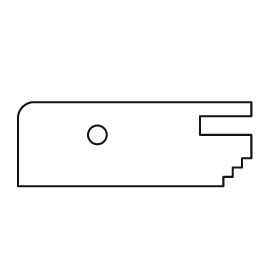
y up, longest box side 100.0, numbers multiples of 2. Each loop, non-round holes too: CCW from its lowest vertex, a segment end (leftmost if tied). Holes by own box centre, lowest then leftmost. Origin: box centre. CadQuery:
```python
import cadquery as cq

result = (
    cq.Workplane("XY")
    .moveTo(-50.0, -18.0)
    .lineTo(38.0, -18.0)
    .lineTo(38.0, -14.0)
    .lineTo(42.0, -14.0)
    .lineTo(42.0, -10.0)
    .lineTo(46.0, -10.0)
    .lineTo(46.0, -6.0)
    .lineTo(50.0, -6.0)
    .lineTo(50.0, 4.0)
    .lineTo(28.0, 4.0)
    .lineTo(28.0, 12.0)
    .lineTo(50.0, 12.0)
    .lineTo(50.0, 18.0)
    .lineTo(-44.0, 18.0)
    .threePointArc((-48.0, 16.0), (-50.0, 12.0))
    .close()
    .moveTo(-16.0, 4.0)
    .circle(4.0)
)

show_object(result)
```